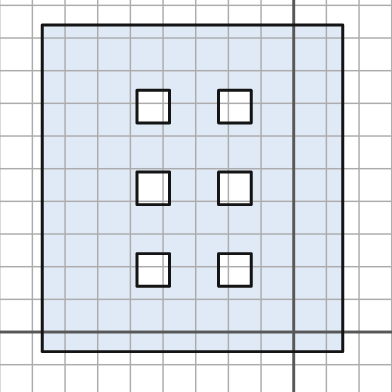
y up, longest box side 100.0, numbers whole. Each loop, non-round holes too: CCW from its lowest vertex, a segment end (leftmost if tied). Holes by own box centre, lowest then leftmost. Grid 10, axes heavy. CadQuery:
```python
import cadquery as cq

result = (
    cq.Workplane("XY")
    .moveTo(-77.0, -6.0)
    .lineTo(15.0, -6.0)
    .lineTo(15.0, 94.0)
    .lineTo(-77.0, 94.0)
    .close()
    .moveTo(-48.0, 14.0)
    .lineTo(-38.0, 14.0)
    .lineTo(-38.0, 24.0)
    .lineTo(-48.0, 24.0)
    .close()
    .moveTo(-23.0, 14.0)
    .lineTo(-13.0, 14.0)
    .lineTo(-13.0, 24.0)
    .lineTo(-23.0, 24.0)
    .close()
    .moveTo(-48.0, 39.0)
    .lineTo(-38.0, 39.0)
    .lineTo(-38.0, 49.0)
    .lineTo(-48.0, 49.0)
    .close()
    .moveTo(-23.0, 39.0)
    .lineTo(-13.0, 39.0)
    .lineTo(-13.0, 49.0)
    .lineTo(-23.0, 49.0)
    .close()
    .moveTo(-48.0, 64.0)
    .lineTo(-38.0, 64.0)
    .lineTo(-38.0, 74.0)
    .lineTo(-48.0, 74.0)
    .close()
    .moveTo(-23.0, 64.0)
    .lineTo(-13.0, 64.0)
    .lineTo(-13.0, 74.0)
    .lineTo(-23.0, 74.0)
    .close()
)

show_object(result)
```